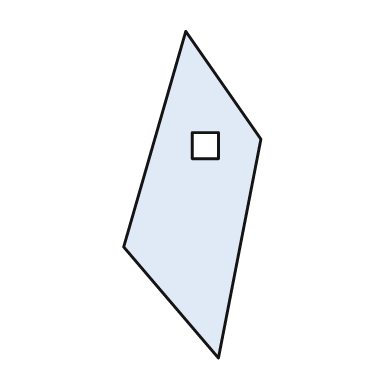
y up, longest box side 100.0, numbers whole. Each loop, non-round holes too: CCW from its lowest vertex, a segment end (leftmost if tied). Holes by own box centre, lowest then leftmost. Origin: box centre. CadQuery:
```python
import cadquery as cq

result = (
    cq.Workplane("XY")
    .moveTo(8.0, -50.0)
    .lineTo(21.0, 17.0)
    .lineTo(-2.0, 50.0)
    .lineTo(-21.0, -16.0)
    .close()
    .moveTo(0.0, 11.0)
    .lineTo(8.0, 11.0)
    .lineTo(8.0, 19.0)
    .lineTo(0.0, 19.0)
    .close()
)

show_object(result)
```